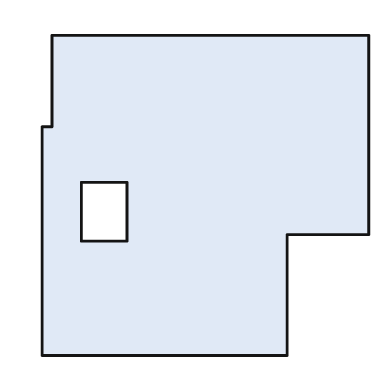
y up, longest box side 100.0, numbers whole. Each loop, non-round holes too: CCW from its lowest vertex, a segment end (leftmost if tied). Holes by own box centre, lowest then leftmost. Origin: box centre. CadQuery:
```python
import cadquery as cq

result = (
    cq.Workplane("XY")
    .moveTo(-50.0, -49.0)
    .lineTo(25.0, -49.0)
    .lineTo(25.0, -12.0)
    .lineTo(50.0, -12.0)
    .lineTo(50.0, 49.0)
    .lineTo(-47.0, 49.0)
    .lineTo(-47.0, 21.0)
    .lineTo(-50.0, 21.0)
    .close()
    .moveTo(-38.0, -14.0)
    .lineTo(-24.0, -14.0)
    .lineTo(-24.0, 4.0)
    .lineTo(-38.0, 4.0)
    .close()
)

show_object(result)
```